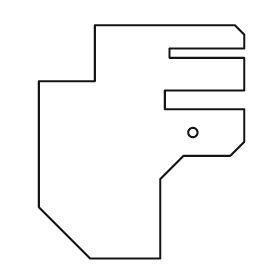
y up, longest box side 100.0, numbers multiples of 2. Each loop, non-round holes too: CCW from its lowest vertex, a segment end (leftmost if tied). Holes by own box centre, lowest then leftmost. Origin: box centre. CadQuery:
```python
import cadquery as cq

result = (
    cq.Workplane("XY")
    .moveTo(-22.0, -50.0)
    .lineTo(8.0, -50.0)
    .lineTo(8.0, -16.0)
    .lineTo(18.0, -6.0)
    .lineTo(38.0, -6.0)
    .lineTo(44.0, 0.0)
    .lineTo(44.0, 14.0)
    .lineTo(10.0, 14.0)
    .lineTo(10.0, 22.0)
    .lineTo(44.0, 22.0)
    .lineTo(44.0, 36.0)
    .lineTo(12.0, 36.0)
    .lineTo(12.0, 40.0)
    .lineTo(44.0, 40.0)
    .lineTo(44.0, 46.0)
    .lineTo(40.0, 50.0)
    .lineTo(-20.0, 50.0)
    .lineTo(-20.0, 26.0)
    .lineTo(-44.0, 26.0)
    .lineTo(-44.0, -28.0)
    .close()
    .moveTo(22.0, 4.0)
    .circle(2.0)
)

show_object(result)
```